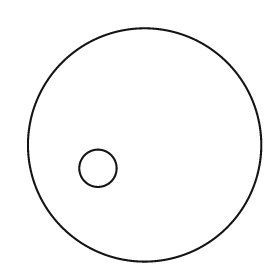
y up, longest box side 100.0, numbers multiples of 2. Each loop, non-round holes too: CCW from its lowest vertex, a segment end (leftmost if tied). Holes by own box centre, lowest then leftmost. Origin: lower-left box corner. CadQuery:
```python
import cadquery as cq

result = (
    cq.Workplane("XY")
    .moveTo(50.0, 50.0)
    .circle(50.0)
    .moveTo(30.0, 40.0)
    .circle(8.0)
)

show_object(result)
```